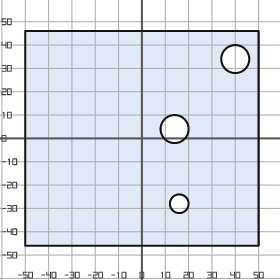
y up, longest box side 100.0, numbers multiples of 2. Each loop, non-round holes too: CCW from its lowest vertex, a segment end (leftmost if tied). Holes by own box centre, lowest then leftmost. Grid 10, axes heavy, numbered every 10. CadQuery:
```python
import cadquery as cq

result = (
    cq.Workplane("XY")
    .moveTo(-50.0, -46.0)
    .lineTo(50.0, -46.0)
    .lineTo(50.0, 46.0)
    .lineTo(-50.0, 46.0)
    .close()
    .moveTo(16.0, -28.0)
    .circle(4.0)
    .moveTo(14.0, 4.0)
    .circle(6.0)
    .moveTo(40.0, 34.0)
    .circle(6.0)
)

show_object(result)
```